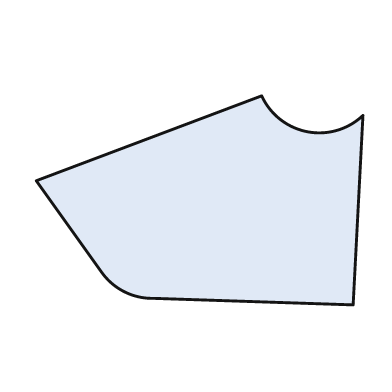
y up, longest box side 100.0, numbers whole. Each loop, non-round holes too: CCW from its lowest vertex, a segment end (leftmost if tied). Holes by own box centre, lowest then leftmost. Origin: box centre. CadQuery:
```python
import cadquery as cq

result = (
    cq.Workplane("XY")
    .moveTo(47.0, -32.0)
    .lineTo(50.0, 26.0)
    .threePointArc((33.0, 21.0), (19.0, 32.0))
    .lineTo(-50.0, 6.0)
    .lineTo(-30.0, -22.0)
    .threePointArc((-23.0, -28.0), (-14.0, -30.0))
    .close()
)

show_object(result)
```